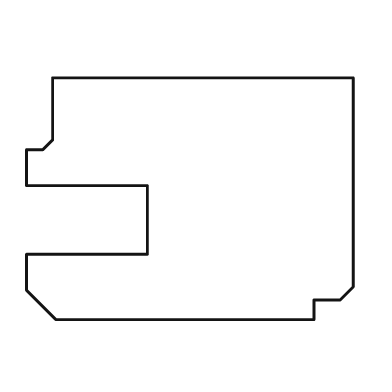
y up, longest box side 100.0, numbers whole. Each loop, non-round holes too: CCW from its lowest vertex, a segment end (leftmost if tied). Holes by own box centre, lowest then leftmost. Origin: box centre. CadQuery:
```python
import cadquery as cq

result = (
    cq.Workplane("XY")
    .moveTo(-41.0, -37.0)
    .lineTo(38.0, -37.0)
    .lineTo(38.0, -31.0)
    .lineTo(46.0, -31.0)
    .lineTo(50.0, -27.0)
    .lineTo(50.0, 37.0)
    .lineTo(-42.0, 37.0)
    .lineTo(-42.0, 18.0)
    .lineTo(-45.0, 15.0)
    .lineTo(-50.0, 15.0)
    .lineTo(-50.0, 4.0)
    .lineTo(-13.0, 4.0)
    .lineTo(-13.0, -17.0)
    .lineTo(-50.0, -17.0)
    .lineTo(-50.0, -28.0)
    .close()
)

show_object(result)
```